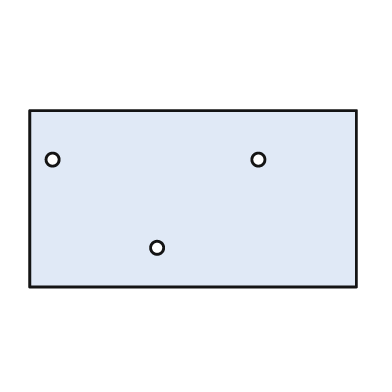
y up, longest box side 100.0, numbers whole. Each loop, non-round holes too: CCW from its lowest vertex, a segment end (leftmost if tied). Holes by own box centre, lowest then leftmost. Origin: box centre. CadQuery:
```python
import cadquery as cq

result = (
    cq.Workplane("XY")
    .moveTo(-50.0, -27.0)
    .lineTo(50.0, -27.0)
    .lineTo(50.0, 27.0)
    .lineTo(-50.0, 27.0)
    .close()
    .moveTo(-11.0, -15.0)
    .circle(2.0)
    .moveTo(-43.0, 12.0)
    .circle(2.0)
    .moveTo(20.0, 12.0)
    .circle(2.0)
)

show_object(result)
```